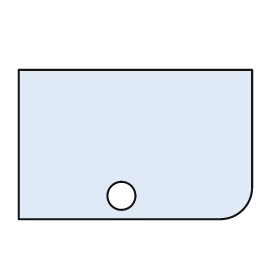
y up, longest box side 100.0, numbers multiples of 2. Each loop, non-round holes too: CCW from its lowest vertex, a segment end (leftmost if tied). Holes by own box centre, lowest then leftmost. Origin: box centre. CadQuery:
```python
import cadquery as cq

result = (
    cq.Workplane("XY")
    .moveTo(-50.0, -32.0)
    .lineTo(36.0, -32.0)
    .threePointArc((46.0, -28.0), (50.0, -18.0))
    .lineTo(50.0, 32.0)
    .lineTo(-50.0, 32.0)
    .close()
    .moveTo(-6.0, -22.0)
    .circle(6.0)
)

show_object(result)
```